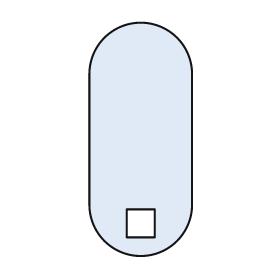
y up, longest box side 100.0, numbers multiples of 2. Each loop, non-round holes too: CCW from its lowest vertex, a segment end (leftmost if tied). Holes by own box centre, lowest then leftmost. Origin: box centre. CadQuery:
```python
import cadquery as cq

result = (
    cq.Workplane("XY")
    .moveTo(-22.0, -28.0)
    .threePointArc((0.0, -50.0), (22.0, -28.0))
    .lineTo(22.0, 28.0)
    .threePointArc((0.0, 50.0), (-22.0, 28.0))
    .close()
    .moveTo(-6.0, -42.0)
    .lineTo(6.0, -42.0)
    .lineTo(6.0, -30.0)
    .lineTo(-6.0, -30.0)
    .close()
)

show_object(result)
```